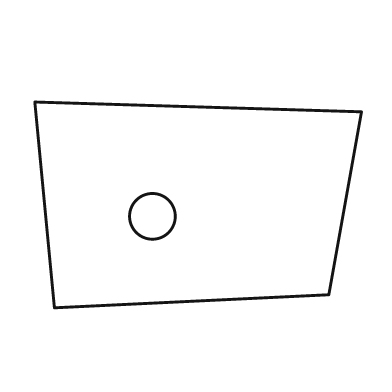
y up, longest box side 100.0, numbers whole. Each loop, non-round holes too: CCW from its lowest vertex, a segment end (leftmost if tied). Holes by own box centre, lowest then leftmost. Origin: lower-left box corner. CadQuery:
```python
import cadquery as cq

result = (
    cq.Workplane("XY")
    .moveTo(6.0, 0.0)
    .lineTo(90.0, 4.0)
    .lineTo(100.0, 60.0)
    .lineTo(0.0, 63.0)
    .close()
    .moveTo(36.0, 28.0)
    .circle(7.0)
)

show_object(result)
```